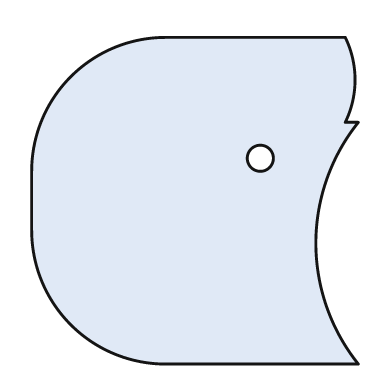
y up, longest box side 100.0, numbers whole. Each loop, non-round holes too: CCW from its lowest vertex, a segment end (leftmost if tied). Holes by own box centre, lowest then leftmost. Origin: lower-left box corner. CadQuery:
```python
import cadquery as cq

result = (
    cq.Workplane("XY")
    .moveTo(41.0, 0.0)
    .lineTo(100.0, 0.0)
    .threePointArc((87.0, 37.0), (100.0, 74.0))
    .lineTo(96.0, 74.0)
    .threePointArc((99.0, 87.0), (96.0, 100.0))
    .lineTo(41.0, 100.0)
    .threePointArc((12.0, 88.0), (0.0, 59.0))
    .lineTo(0.0, 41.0)
    .threePointArc((12.0, 12.0), (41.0, 0.0))
    .close()
    .moveTo(70.0, 63.0)
    .circle(4.0)
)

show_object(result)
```